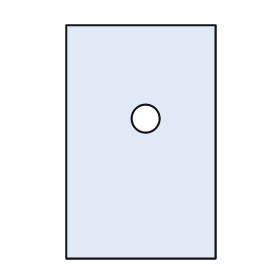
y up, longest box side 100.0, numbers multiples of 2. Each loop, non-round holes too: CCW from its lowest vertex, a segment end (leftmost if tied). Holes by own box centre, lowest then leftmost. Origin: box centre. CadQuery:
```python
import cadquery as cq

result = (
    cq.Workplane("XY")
    .moveTo(-32.0, -50.0)
    .lineTo(32.0, -50.0)
    .lineTo(32.0, 50.0)
    .lineTo(-32.0, 50.0)
    .close()
    .moveTo(2.0, 10.0)
    .circle(6.0)
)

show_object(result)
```